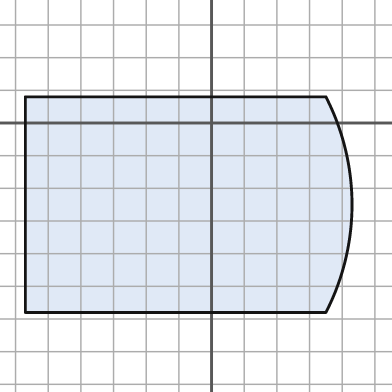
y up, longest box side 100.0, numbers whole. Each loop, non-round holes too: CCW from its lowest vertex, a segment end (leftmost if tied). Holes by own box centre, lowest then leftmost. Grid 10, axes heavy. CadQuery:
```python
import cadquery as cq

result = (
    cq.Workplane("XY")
    .moveTo(-57.0, -58.0)
    .lineTo(35.0, -58.0)
    .threePointArc((43.0, -25.0), (35.0, 8.0))
    .lineTo(-57.0, 8.0)
    .close()
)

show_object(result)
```